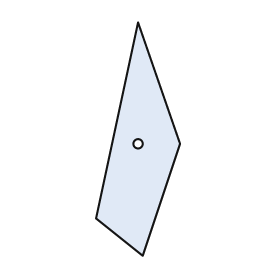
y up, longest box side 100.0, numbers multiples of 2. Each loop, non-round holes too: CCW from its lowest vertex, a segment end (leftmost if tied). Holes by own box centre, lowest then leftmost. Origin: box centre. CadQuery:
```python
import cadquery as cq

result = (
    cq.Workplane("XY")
    .moveTo(2.0, -50.0)
    .lineTo(18.0, -2.0)
    .lineTo(0.0, 50.0)
    .lineTo(-18.0, -34.0)
    .close()
    .moveTo(0.0, -2.0)
    .circle(2.0)
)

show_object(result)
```